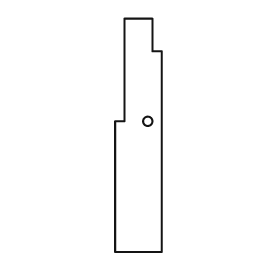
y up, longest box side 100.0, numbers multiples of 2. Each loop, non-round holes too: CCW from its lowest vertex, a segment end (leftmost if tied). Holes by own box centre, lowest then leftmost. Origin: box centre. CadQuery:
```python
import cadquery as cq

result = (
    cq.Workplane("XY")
    .moveTo(-10.0, -50.0)
    .lineTo(10.0, -50.0)
    .lineTo(10.0, 36.0)
    .lineTo(6.0, 36.0)
    .lineTo(6.0, 50.0)
    .lineTo(-6.0, 50.0)
    .lineTo(-6.0, 6.0)
    .lineTo(-10.0, 6.0)
    .close()
    .moveTo(4.0, 6.0)
    .circle(2.0)
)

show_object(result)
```